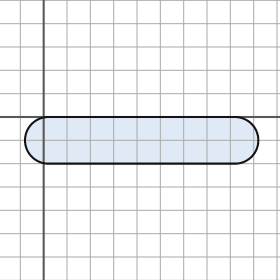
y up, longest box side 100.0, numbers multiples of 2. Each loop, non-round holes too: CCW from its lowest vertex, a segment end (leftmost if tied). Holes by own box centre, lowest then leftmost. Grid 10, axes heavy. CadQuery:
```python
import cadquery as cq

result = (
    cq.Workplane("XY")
    .moveTo(2.0, -20.0)
    .lineTo(82.0, -20.0)
    .threePointArc((92.0, -10.0), (82.0, 0.0))
    .lineTo(2.0, 0.0)
    .threePointArc((-8.0, -10.0), (2.0, -20.0))
    .close()
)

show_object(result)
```